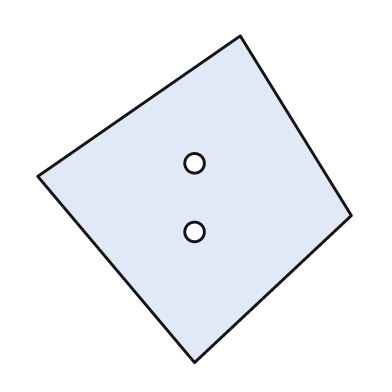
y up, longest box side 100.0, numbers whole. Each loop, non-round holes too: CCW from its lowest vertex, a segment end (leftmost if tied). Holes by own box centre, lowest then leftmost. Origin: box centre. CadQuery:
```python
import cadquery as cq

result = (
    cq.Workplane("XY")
    .moveTo(0.0, -50.0)
    .lineTo(48.0, -5.0)
    .lineTo(14.0, 50.0)
    .lineTo(-48.0, 7.0)
    .close()
    .moveTo(0.0, -10.0)
    .circle(3.0)
    .moveTo(0.0, 11.0)
    .circle(3.0)
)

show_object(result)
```